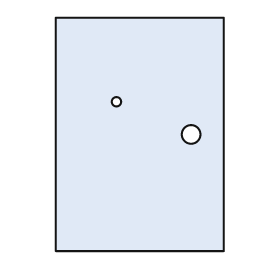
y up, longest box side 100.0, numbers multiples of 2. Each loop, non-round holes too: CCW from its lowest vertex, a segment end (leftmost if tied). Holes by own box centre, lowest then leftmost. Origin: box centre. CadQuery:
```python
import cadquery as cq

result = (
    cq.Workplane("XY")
    .moveTo(-36.0, -50.0)
    .lineTo(36.0, -50.0)
    .lineTo(36.0, 50.0)
    .lineTo(-36.0, 50.0)
    .close()
    .moveTo(22.0, 0.0)
    .circle(4.0)
    .moveTo(-10.0, 14.0)
    .circle(2.0)
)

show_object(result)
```